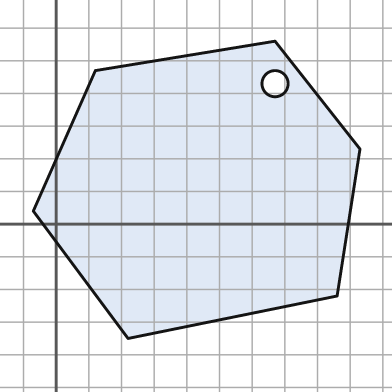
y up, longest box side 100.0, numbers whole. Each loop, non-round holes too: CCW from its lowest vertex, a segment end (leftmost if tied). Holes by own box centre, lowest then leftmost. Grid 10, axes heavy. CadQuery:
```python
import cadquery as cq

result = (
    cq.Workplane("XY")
    .moveTo(22.0, -35.0)
    .lineTo(86.0, -22.0)
    .lineTo(93.0, 23.0)
    .lineTo(67.0, 56.0)
    .lineTo(12.0, 47.0)
    .lineTo(-7.0, 4.0)
    .close()
    .moveTo(67.0, 43.0)
    .circle(4.0)
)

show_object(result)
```